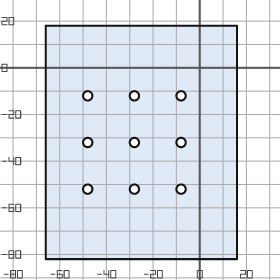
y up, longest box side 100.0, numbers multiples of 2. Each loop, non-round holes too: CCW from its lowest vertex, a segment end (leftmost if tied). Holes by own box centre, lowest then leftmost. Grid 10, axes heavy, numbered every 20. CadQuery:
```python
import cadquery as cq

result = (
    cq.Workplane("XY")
    .moveTo(-66.0, -82.0)
    .lineTo(16.0, -82.0)
    .lineTo(16.0, 18.0)
    .lineTo(-66.0, 18.0)
    .close()
    .moveTo(-48.0, -52.0)
    .circle(2.0)
    .moveTo(-28.0, -52.0)
    .circle(2.0)
    .moveTo(-8.0, -52.0)
    .circle(2.0)
    .moveTo(-48.0, -32.0)
    .circle(2.0)
    .moveTo(-28.0, -32.0)
    .circle(2.0)
    .moveTo(-8.0, -32.0)
    .circle(2.0)
    .moveTo(-48.0, -12.0)
    .circle(2.0)
    .moveTo(-28.0, -12.0)
    .circle(2.0)
    .moveTo(-8.0, -12.0)
    .circle(2.0)
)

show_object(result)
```